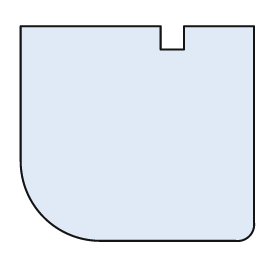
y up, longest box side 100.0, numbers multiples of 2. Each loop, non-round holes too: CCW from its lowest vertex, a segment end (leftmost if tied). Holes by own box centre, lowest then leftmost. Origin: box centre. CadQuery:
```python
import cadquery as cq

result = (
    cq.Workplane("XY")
    .moveTo(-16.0, -46.0)
    .lineTo(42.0, -46.0)
    .threePointArc((48.0, -44.0), (50.0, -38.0))
    .lineTo(50.0, 46.0)
    .lineTo(20.0, 46.0)
    .lineTo(20.0, 36.0)
    .lineTo(10.0, 36.0)
    .lineTo(10.0, 46.0)
    .lineTo(-50.0, 46.0)
    .lineTo(-50.0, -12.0)
    .threePointArc((-40.0, -36.0), (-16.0, -46.0))
    .close()
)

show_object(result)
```